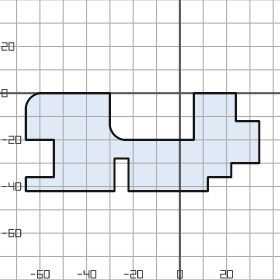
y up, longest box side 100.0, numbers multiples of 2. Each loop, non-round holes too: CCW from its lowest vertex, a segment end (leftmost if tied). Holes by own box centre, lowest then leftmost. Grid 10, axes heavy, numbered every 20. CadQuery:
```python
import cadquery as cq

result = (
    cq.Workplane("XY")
    .moveTo(-66.0, -42.0)
    .lineTo(-28.0, -42.0)
    .lineTo(-28.0, -28.0)
    .lineTo(-22.0, -28.0)
    .lineTo(-22.0, -42.0)
    .lineTo(12.0, -42.0)
    .lineTo(12.0, -36.0)
    .lineTo(22.0, -36.0)
    .lineTo(22.0, -30.0)
    .lineTo(34.0, -30.0)
    .lineTo(34.0, -12.0)
    .lineTo(24.0, -12.0)
    .lineTo(24.0, 0.0)
    .lineTo(6.0, 0.0)
    .lineTo(6.0, -20.0)
    .lineTo(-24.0, -20.0)
    .threePointArc((-28.0, -18.0), (-30.0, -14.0))
    .lineTo(-30.0, 0.0)
    .lineTo(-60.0, 0.0)
    .threePointArc((-64.0, -2.0), (-66.0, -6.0))
    .lineTo(-66.0, -20.0)
    .lineTo(-54.0, -20.0)
    .lineTo(-54.0, -36.0)
    .lineTo(-66.0, -36.0)
    .close()
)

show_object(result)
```